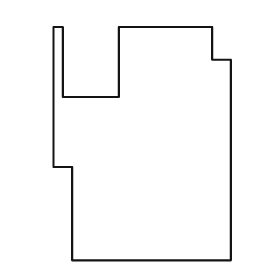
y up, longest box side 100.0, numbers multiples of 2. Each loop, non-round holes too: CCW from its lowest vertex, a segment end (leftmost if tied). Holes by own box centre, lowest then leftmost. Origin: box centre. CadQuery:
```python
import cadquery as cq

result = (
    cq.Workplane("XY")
    .moveTo(-30.0, -50.0)
    .lineTo(38.0, -50.0)
    .lineTo(38.0, 36.0)
    .lineTo(30.0, 36.0)
    .lineTo(30.0, 50.0)
    .lineTo(-10.0, 50.0)
    .lineTo(-10.0, 20.0)
    .lineTo(-34.0, 20.0)
    .lineTo(-34.0, 50.0)
    .lineTo(-38.0, 50.0)
    .lineTo(-38.0, -10.0)
    .lineTo(-30.0, -10.0)
    .close()
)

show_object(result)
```